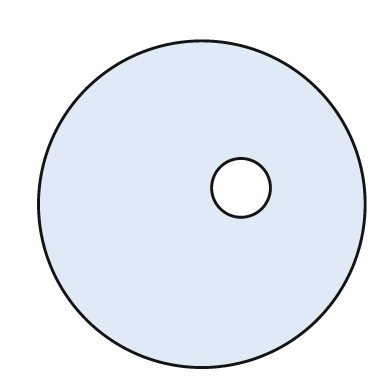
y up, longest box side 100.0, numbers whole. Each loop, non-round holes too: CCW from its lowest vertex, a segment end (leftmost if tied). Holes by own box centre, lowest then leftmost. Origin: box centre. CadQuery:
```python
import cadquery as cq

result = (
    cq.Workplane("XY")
    .moveTo(0.0, 0.0)
    .circle(50.0)
    .moveTo(12.0, 5.0)
    .circle(9.0)
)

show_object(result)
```